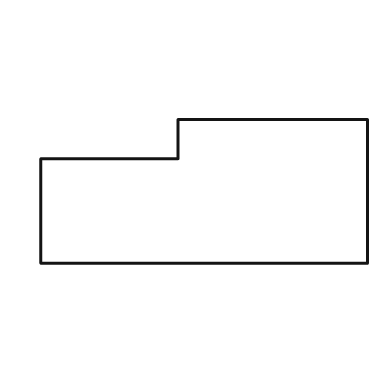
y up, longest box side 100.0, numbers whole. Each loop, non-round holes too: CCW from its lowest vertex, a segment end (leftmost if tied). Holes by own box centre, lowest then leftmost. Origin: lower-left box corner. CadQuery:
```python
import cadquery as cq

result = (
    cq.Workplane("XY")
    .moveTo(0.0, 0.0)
    .lineTo(100.0, 0.0)
    .lineTo(100.0, 44.0)
    .lineTo(42.0, 44.0)
    .lineTo(42.0, 32.0)
    .lineTo(0.0, 32.0)
    .close()
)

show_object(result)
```